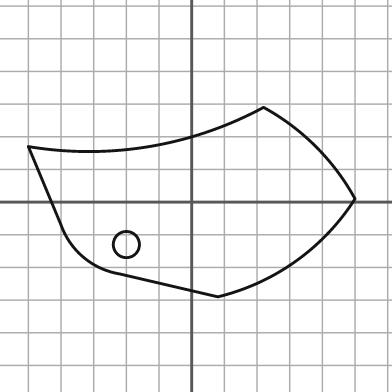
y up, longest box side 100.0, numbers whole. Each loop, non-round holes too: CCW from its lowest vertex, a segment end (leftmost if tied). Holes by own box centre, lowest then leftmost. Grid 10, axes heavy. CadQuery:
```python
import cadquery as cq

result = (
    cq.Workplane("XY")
    .moveTo(8.0, -29.0)
    .threePointArc((32.0, -18.0), (50.0, 1.0))
    .threePointArc((38.0, 17.0), (22.0, 29.0))
    .threePointArc((-13.0, 17.0), (-50.0, 17.0))
    .lineTo(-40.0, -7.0)
    .threePointArc((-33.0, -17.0), (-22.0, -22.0))
    .close()
    .moveTo(-20.0, -13.0)
    .circle(4.0)
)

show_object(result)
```